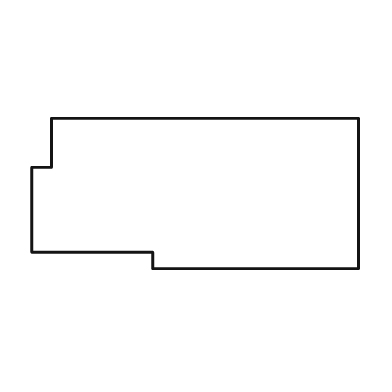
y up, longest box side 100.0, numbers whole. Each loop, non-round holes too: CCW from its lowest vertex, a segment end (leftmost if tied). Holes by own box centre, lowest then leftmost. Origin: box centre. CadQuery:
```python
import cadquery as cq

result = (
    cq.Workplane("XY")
    .moveTo(-13.0, -23.0)
    .lineTo(50.0, -23.0)
    .lineTo(50.0, 23.0)
    .lineTo(-44.0, 23.0)
    .lineTo(-44.0, 8.0)
    .lineTo(-50.0, 8.0)
    .lineTo(-50.0, -18.0)
    .lineTo(-13.0, -18.0)
    .close()
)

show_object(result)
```